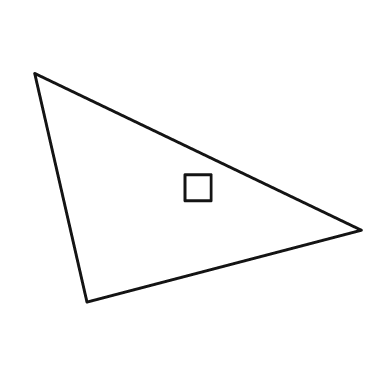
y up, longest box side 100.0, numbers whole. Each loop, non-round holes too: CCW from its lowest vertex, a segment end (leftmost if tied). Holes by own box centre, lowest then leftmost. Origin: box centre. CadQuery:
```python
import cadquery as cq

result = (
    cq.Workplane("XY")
    .moveTo(-34.0, -35.0)
    .lineTo(50.0, -13.0)
    .lineTo(-50.0, 35.0)
    .close()
    .moveTo(-4.0, -4.0)
    .lineTo(4.0, -4.0)
    .lineTo(4.0, 4.0)
    .lineTo(-4.0, 4.0)
    .close()
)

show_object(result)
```